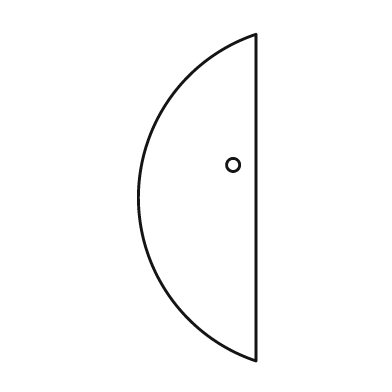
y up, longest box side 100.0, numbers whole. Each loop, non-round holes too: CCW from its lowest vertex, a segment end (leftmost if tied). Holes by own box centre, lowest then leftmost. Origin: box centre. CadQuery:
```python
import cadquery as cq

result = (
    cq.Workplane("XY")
    .moveTo(18.0, -50.0)
    .lineTo(18.0, 50.0)
    .threePointArc((-18.0, 0.0), (18.0, -50.0))
    .close()
    .moveTo(11.0, 10.0)
    .circle(2.0)
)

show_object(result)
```